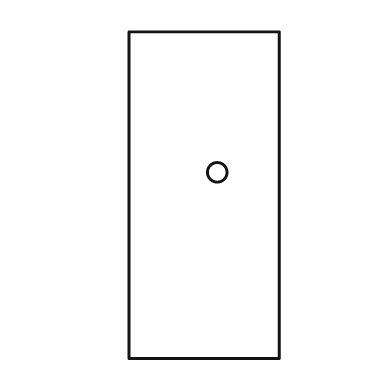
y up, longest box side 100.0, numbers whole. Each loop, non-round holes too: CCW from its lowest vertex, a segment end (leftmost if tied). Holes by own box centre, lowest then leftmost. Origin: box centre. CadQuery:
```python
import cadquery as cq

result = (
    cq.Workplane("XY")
    .moveTo(-23.0, -50.0)
    .lineTo(23.0, -50.0)
    .lineTo(23.0, 50.0)
    .lineTo(-23.0, 50.0)
    .close()
    .moveTo(4.0, 7.0)
    .circle(3.0)
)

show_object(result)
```